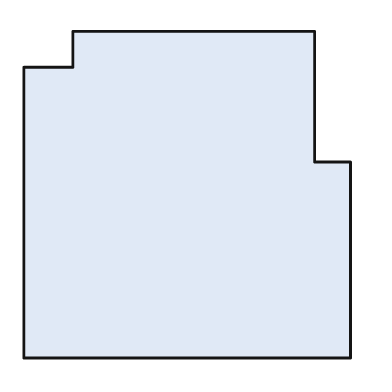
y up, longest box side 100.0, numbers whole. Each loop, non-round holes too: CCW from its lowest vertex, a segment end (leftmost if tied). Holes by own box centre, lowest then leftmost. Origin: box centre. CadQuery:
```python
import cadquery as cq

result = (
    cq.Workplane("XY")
    .moveTo(-50.0, -50.0)
    .lineTo(50.0, -50.0)
    .lineTo(50.0, 10.0)
    .lineTo(39.0, 10.0)
    .lineTo(39.0, 50.0)
    .lineTo(-35.0, 50.0)
    .lineTo(-35.0, 39.0)
    .lineTo(-50.0, 39.0)
    .close()
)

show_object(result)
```